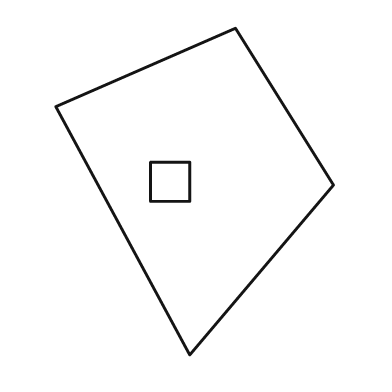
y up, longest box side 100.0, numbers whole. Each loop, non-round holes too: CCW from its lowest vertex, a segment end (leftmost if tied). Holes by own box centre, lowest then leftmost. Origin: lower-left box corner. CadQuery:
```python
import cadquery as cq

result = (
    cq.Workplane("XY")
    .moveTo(41.0, 0.0)
    .lineTo(85.0, 52.0)
    .lineTo(55.0, 100.0)
    .lineTo(0.0, 76.0)
    .close()
    .moveTo(29.0, 47.0)
    .lineTo(41.0, 47.0)
    .lineTo(41.0, 59.0)
    .lineTo(29.0, 59.0)
    .close()
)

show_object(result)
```